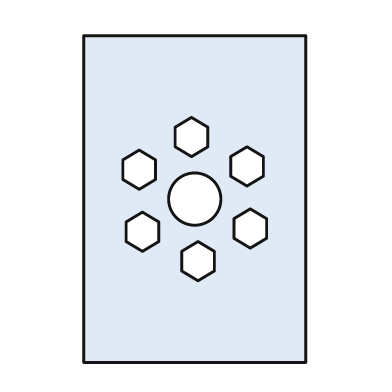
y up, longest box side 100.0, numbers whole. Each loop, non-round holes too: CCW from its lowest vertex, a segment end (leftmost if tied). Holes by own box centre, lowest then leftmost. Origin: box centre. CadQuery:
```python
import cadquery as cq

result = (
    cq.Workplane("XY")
    .moveTo(-34.0, -50.0)
    .lineTo(34.0, -50.0)
    .lineTo(34.0, 50.0)
    .lineTo(-34.0, 50.0)
    .close()
    .moveTo(1.0, -25.0)
    .lineTo(6.0, -22.0)
    .lineTo(6.0, -16.0)
    .lineTo(1.0, -13.0)
    .lineTo(-4.0, -16.0)
    .lineTo(-4.0, -22.0)
    .close()
    .moveTo(-16.0, -16.0)
    .lineTo(-11.0, -13.0)
    .lineTo(-11.0, -7.0)
    .lineTo(-16.0, -4.0)
    .lineTo(-21.0, -7.0)
    .lineTo(-21.0, -13.0)
    .close()
    .moveTo(17.0, -15.0)
    .lineTo(22.0, -12.0)
    .lineTo(22.0, -6.0)
    .lineTo(17.0, -3.0)
    .lineTo(12.0, -6.0)
    .lineTo(12.0, -12.0)
    .close()
    .moveTo(0.0, 0.0)
    .circle(8.0)
    .moveTo(-17.0, 3.0)
    .lineTo(-12.0, 6.0)
    .lineTo(-12.0, 12.0)
    .lineTo(-17.0, 15.0)
    .lineTo(-22.0, 12.0)
    .lineTo(-22.0, 6.0)
    .close()
    .moveTo(16.0, 4.0)
    .lineTo(21.0, 7.0)
    .lineTo(21.0, 13.0)
    .lineTo(16.0, 16.0)
    .lineTo(11.0, 13.0)
    .lineTo(11.0, 7.0)
    .close()
    .moveTo(-1.0, 13.0)
    .lineTo(4.0, 16.0)
    .lineTo(4.0, 22.0)
    .lineTo(-1.0, 25.0)
    .lineTo(-6.0, 22.0)
    .lineTo(-6.0, 16.0)
    .close()
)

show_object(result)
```